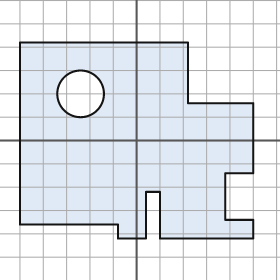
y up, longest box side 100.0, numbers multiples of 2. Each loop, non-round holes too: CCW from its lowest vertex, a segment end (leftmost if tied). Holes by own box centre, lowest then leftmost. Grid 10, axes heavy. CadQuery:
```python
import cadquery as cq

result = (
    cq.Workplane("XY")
    .moveTo(-8.0, -42.0)
    .lineTo(4.0, -42.0)
    .lineTo(4.0, -22.0)
    .lineTo(10.0, -22.0)
    .lineTo(10.0, -42.0)
    .lineTo(50.0, -42.0)
    .lineTo(50.0, -34.0)
    .lineTo(38.0, -34.0)
    .lineTo(38.0, -14.0)
    .lineTo(50.0, -14.0)
    .lineTo(50.0, 16.0)
    .lineTo(22.0, 16.0)
    .lineTo(22.0, 42.0)
    .lineTo(-50.0, 42.0)
    .lineTo(-50.0, -36.0)
    .lineTo(-8.0, -36.0)
    .close()
    .moveTo(-24.0, 20.0)
    .circle(10.0)
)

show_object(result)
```